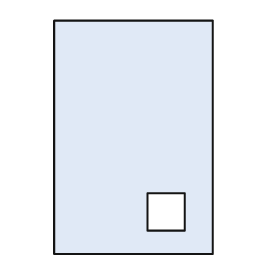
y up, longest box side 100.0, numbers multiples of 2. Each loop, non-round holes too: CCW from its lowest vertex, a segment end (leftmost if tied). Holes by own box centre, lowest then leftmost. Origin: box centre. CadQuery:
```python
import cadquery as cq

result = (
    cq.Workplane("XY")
    .moveTo(-34.0, -50.0)
    .lineTo(34.0, -50.0)
    .lineTo(34.0, 50.0)
    .lineTo(-34.0, 50.0)
    .close()
    .moveTo(6.0, -40.0)
    .lineTo(22.0, -40.0)
    .lineTo(22.0, -24.0)
    .lineTo(6.0, -24.0)
    .close()
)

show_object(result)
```